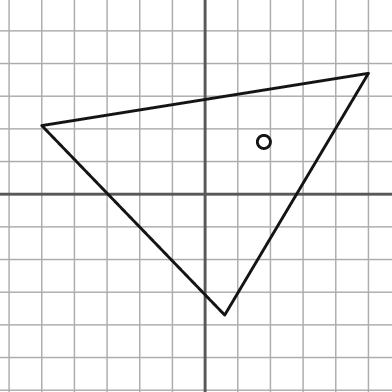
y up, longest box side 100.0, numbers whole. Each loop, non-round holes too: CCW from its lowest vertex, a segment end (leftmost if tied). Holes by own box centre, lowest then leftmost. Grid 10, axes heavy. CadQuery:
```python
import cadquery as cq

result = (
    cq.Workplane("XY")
    .moveTo(6.0, -37.0)
    .lineTo(50.0, 37.0)
    .lineTo(-50.0, 21.0)
    .close()
    .moveTo(18.0, 16.0)
    .circle(2.0)
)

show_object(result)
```